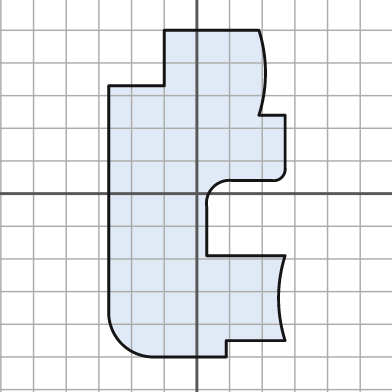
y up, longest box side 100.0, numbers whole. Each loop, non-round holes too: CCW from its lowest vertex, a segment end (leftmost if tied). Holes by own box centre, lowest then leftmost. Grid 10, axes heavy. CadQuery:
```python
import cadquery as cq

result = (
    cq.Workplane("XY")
    .moveTo(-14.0, -50.0)
    .lineTo(9.0, -50.0)
    .lineTo(9.0, -45.0)
    .lineTo(27.0, -45.0)
    .threePointArc((25.0, -32.0), (27.0, -19.0))
    .lineTo(3.0, -19.0)
    .lineTo(3.0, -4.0)
    .threePointArc((5.0, 2.0), (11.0, 4.0))
    .lineTo(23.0, 4.0)
    .threePointArc((26.0, 5.0), (27.0, 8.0))
    .lineTo(27.0, 24.0)
    .lineTo(19.0, 24.0)
    .threePointArc((21.0, 37.0), (19.0, 50.0))
    .lineTo(-10.0, 50.0)
    .lineTo(-10.0, 33.0)
    .lineTo(-27.0, 33.0)
    .lineTo(-27.0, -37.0)
    .threePointArc((-23.0, -46.0), (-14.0, -50.0))
    .close()
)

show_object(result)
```